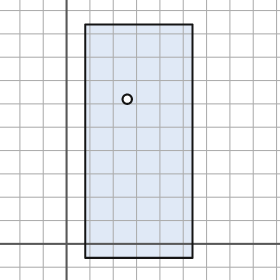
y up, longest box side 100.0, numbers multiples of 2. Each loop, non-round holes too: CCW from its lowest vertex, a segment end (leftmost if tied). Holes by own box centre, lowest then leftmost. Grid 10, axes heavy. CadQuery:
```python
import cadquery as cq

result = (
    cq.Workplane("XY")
    .moveTo(8.0, -6.0)
    .lineTo(54.0, -6.0)
    .lineTo(54.0, 94.0)
    .lineTo(8.0, 94.0)
    .close()
    .moveTo(26.0, 62.0)
    .circle(2.0)
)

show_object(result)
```